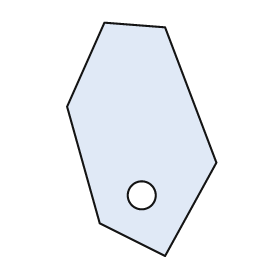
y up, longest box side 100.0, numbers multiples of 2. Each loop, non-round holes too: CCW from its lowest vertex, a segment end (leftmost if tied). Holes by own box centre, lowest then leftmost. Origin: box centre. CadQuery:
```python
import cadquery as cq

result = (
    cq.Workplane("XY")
    .moveTo(10.0, -50.0)
    .lineTo(32.0, -10.0)
    .lineTo(10.0, 48.0)
    .lineTo(-16.0, 50.0)
    .lineTo(-32.0, 14.0)
    .lineTo(-18.0, -36.0)
    .close()
    .moveTo(0.0, -24.0)
    .circle(6.0)
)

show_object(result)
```